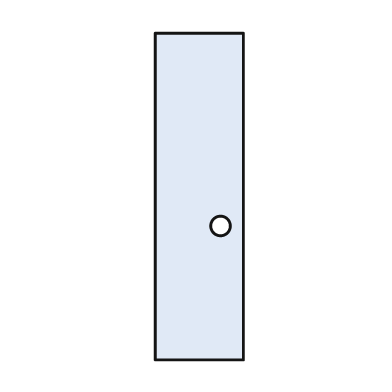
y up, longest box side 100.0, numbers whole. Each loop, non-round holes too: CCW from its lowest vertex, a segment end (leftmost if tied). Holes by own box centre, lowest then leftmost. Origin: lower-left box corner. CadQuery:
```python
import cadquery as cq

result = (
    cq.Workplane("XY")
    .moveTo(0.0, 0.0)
    .lineTo(27.0, 0.0)
    .lineTo(27.0, 100.0)
    .lineTo(0.0, 100.0)
    .close()
    .moveTo(20.0, 41.0)
    .circle(3.0)
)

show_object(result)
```